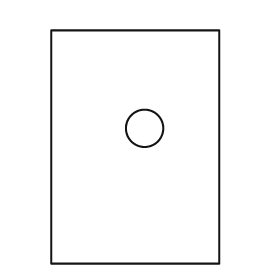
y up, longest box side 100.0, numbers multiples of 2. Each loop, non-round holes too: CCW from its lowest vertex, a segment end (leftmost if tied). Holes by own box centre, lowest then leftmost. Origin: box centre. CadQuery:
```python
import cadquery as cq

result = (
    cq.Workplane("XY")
    .moveTo(-36.0, -50.0)
    .lineTo(36.0, -50.0)
    .lineTo(36.0, 50.0)
    .lineTo(-36.0, 50.0)
    .close()
    .moveTo(4.0, 8.0)
    .circle(8.0)
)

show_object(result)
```